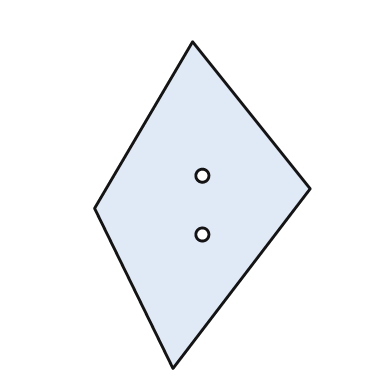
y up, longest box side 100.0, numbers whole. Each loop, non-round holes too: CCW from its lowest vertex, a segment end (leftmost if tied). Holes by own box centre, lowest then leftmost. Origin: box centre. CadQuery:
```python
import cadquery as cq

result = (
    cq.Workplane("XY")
    .moveTo(-9.0, -50.0)
    .lineTo(33.0, 5.0)
    .lineTo(-3.0, 50.0)
    .lineTo(-33.0, -1.0)
    .close()
    .moveTo(0.0, -9.0)
    .circle(2.0)
    .moveTo(0.0, 9.0)
    .circle(2.0)
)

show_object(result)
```